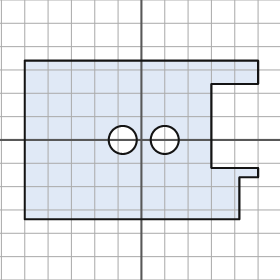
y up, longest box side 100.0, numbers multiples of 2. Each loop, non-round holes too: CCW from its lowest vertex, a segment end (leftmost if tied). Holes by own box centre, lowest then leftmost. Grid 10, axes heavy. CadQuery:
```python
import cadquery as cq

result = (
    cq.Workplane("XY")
    .moveTo(-50.0, -34.0)
    .lineTo(42.0, -34.0)
    .lineTo(42.0, -16.0)
    .lineTo(50.0, -16.0)
    .lineTo(50.0, -12.0)
    .lineTo(30.0, -12.0)
    .lineTo(30.0, 24.0)
    .lineTo(50.0, 24.0)
    .lineTo(50.0, 34.0)
    .lineTo(-50.0, 34.0)
    .close()
    .moveTo(-8.0, 0.0)
    .circle(6.0)
    .moveTo(10.0, 0.0)
    .circle(6.0)
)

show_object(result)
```